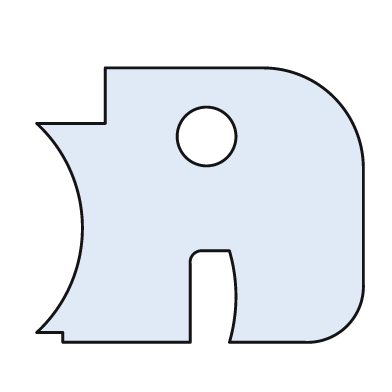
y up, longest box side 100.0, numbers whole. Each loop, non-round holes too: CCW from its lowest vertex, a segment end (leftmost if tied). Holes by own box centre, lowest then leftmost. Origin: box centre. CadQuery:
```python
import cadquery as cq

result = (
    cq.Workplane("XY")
    .moveTo(-42.0, -42.0)
    .lineTo(-3.0, -42.0)
    .lineTo(-3.0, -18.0)
    .threePointArc((-2.0, -15.0), (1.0, -14.0))
    .lineTo(9.0, -14.0)
    .threePointArc((11.0, -28.0), (9.0, -42.0))
    .lineTo(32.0, -42.0)
    .threePointArc((45.0, -37.0), (50.0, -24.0))
    .lineTo(50.0, 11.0)
    .threePointArc((41.0, 33.0), (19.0, 42.0))
    .lineTo(-29.0, 42.0)
    .lineTo(-29.0, 25.0)
    .lineTo(-50.0, 25.0)
    .threePointArc((-36.0, -7.0), (-50.0, -39.0))
    .lineTo(-42.0, -39.0)
    .close()
    .moveTo(2.0, 21.0)
    .circle(9.0)
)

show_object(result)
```